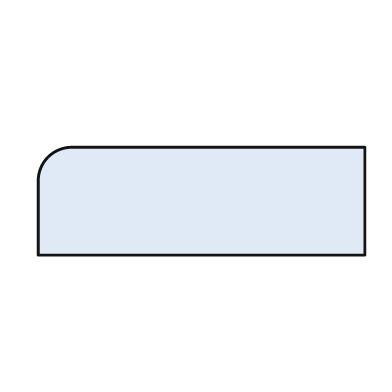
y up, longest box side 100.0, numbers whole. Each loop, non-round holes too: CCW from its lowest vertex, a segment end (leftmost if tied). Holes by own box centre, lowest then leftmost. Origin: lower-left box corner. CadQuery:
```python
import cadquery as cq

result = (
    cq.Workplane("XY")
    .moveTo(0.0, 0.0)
    .lineTo(100.0, 0.0)
    .lineTo(100.0, 33.0)
    .lineTo(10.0, 33.0)
    .threePointArc((3.0, 30.0), (0.0, 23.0))
    .close()
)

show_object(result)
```